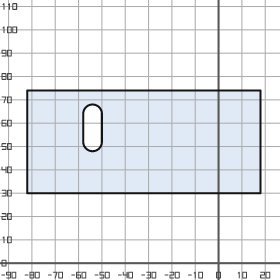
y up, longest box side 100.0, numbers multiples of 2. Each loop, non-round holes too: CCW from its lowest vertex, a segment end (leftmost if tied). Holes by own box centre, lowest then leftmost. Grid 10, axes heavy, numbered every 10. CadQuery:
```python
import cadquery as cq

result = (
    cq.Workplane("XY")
    .moveTo(-82.0, 30.0)
    .lineTo(18.0, 30.0)
    .lineTo(18.0, 74.0)
    .lineTo(-82.0, 74.0)
    .close()
    .moveTo(-58.0, 52.0)
    .threePointArc((-54.0, 48.0), (-50.0, 52.0))
    .lineTo(-50.0, 64.0)
    .threePointArc((-54.0, 68.0), (-58.0, 64.0))
    .close()
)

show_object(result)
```